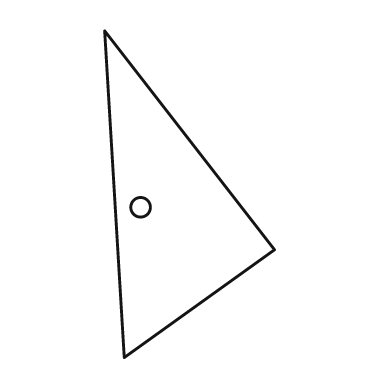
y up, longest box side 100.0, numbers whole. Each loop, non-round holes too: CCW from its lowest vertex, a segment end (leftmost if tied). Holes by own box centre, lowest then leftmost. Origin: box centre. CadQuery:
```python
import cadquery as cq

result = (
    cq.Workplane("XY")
    .moveTo(-20.0, -50.0)
    .lineTo(26.0, -17.0)
    .lineTo(-26.0, 50.0)
    .close()
    .moveTo(-15.0, -4.0)
    .circle(3.0)
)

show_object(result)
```